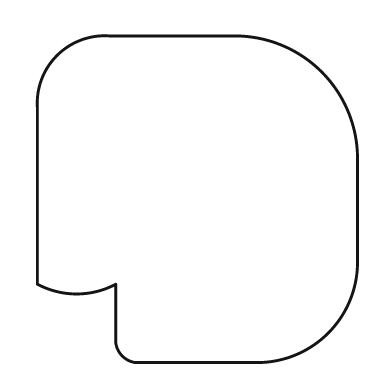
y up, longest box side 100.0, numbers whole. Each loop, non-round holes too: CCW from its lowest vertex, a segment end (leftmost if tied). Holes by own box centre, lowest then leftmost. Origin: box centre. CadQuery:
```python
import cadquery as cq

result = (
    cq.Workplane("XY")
    .moveTo(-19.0, -50.0)
    .lineTo(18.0, -50.0)
    .threePointArc((40.0, -41.0), (49.0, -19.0))
    .lineTo(49.0, 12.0)
    .threePointArc((38.0, 39.0), (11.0, 50.0))
    .lineTo(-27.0, 50.0)
    .threePointArc((-43.0, 44.0), (-49.0, 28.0))
    .lineTo(-49.0, -26.0)
    .threePointArc((-37.0, -29.0), (-25.0, -26.0))
    .lineTo(-25.0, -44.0)
    .threePointArc((-23.0, -48.0), (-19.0, -50.0))
    .close()
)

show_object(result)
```